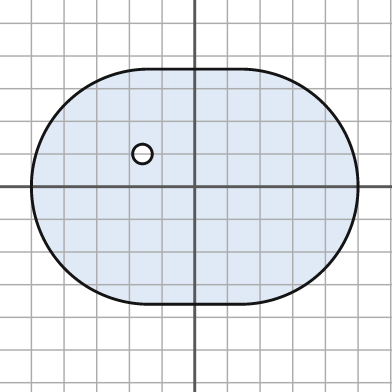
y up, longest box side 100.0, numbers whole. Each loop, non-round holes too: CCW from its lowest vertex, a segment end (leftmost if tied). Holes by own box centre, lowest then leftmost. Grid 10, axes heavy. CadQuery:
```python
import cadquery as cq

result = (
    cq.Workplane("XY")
    .moveTo(-14.0, -36.0)
    .lineTo(14.0, -36.0)
    .threePointArc((50.0, 0.0), (14.0, 36.0))
    .lineTo(-14.0, 36.0)
    .threePointArc((-50.0, 0.0), (-14.0, -36.0))
    .close()
    .moveTo(-16.0, 10.0)
    .circle(3.0)
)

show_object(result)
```